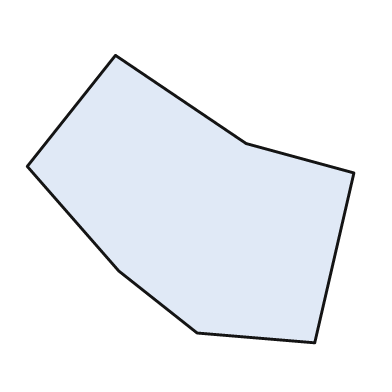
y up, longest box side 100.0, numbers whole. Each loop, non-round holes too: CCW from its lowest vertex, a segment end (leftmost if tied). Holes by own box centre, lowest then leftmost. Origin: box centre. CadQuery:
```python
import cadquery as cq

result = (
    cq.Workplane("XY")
    .moveTo(38.0, -44.0)
    .lineTo(50.0, 8.0)
    .lineTo(17.0, 17.0)
    .lineTo(-23.0, 44.0)
    .lineTo(-50.0, 10.0)
    .lineTo(-22.0, -22.0)
    .lineTo(2.0, -41.0)
    .close()
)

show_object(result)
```